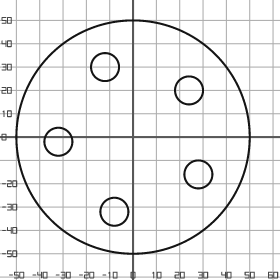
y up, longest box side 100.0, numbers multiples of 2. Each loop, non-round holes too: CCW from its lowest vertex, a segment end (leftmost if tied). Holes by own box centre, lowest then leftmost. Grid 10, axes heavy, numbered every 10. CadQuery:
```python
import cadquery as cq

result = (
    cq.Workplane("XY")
    .moveTo(0.0, 0.0)
    .circle(50.0)
    .moveTo(-8.0, -32.0)
    .circle(6.0)
    .moveTo(28.0, -16.0)
    .circle(6.0)
    .moveTo(-32.0, -2.0)
    .circle(6.0)
    .moveTo(24.0, 20.0)
    .circle(6.0)
    .moveTo(-12.0, 30.0)
    .circle(6.0)
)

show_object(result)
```